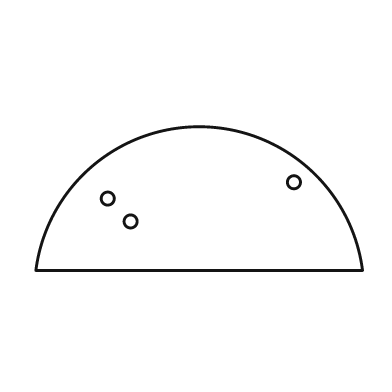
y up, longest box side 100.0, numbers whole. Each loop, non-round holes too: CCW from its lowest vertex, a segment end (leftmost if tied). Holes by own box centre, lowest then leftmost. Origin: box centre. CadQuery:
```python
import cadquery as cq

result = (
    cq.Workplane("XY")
    .moveTo(-50.0, -22.0)
    .lineTo(50.0, -22.0)
    .threePointArc((0.0, 22.0), (-50.0, -22.0))
    .close()
    .moveTo(-21.0, -7.0)
    .circle(2.0)
    .moveTo(-28.0, 0.0)
    .circle(2.0)
    .moveTo(29.0, 5.0)
    .circle(2.0)
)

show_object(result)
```